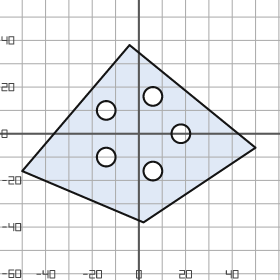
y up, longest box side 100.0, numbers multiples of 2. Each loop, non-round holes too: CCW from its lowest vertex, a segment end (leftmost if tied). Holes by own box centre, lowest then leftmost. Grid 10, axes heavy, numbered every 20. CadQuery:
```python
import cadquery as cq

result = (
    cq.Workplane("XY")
    .moveTo(2.0, -38.0)
    .lineTo(50.0, -6.0)
    .lineTo(-4.0, 38.0)
    .lineTo(-50.0, -16.0)
    .close()
    .moveTo(6.0, -16.0)
    .circle(4.0)
    .moveTo(-14.0, -10.0)
    .circle(4.0)
    .moveTo(18.0, 0.0)
    .circle(4.0)
    .moveTo(-14.0, 10.0)
    .circle(4.0)
    .moveTo(6.0, 16.0)
    .circle(4.0)
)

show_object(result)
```